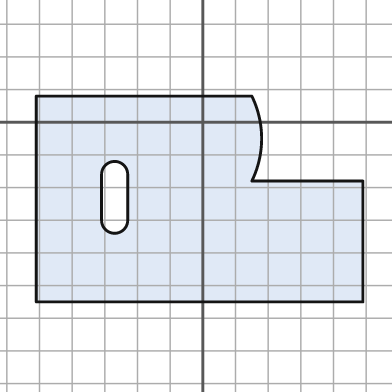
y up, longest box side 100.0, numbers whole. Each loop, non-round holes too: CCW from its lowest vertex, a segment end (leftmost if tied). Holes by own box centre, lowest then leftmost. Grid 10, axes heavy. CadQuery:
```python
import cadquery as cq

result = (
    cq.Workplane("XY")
    .moveTo(-51.0, -55.0)
    .lineTo(49.0, -55.0)
    .lineTo(49.0, -18.0)
    .lineTo(15.0, -18.0)
    .threePointArc((18.0, -5.0), (15.0, 8.0))
    .lineTo(-51.0, 8.0)
    .close()
    .moveTo(-31.0, -30.0)
    .threePointArc((-27.0, -34.0), (-23.0, -30.0))
    .lineTo(-23.0, -16.0)
    .threePointArc((-27.0, -12.0), (-31.0, -16.0))
    .close()
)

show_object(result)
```